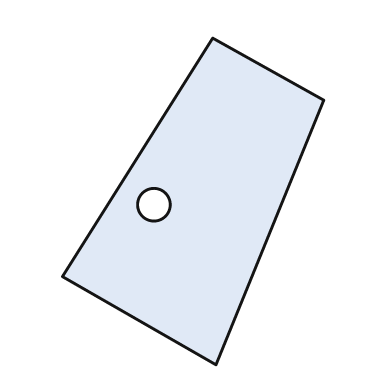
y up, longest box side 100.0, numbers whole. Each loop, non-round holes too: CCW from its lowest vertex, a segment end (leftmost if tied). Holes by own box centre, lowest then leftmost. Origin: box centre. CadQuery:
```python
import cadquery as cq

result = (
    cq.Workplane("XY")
    .moveTo(7.0, -50.0)
    .lineTo(40.0, 31.0)
    .lineTo(6.0, 50.0)
    .lineTo(-40.0, -23.0)
    .close()
    .moveTo(-12.0, -1.0)
    .circle(5.0)
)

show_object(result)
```